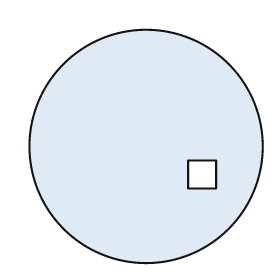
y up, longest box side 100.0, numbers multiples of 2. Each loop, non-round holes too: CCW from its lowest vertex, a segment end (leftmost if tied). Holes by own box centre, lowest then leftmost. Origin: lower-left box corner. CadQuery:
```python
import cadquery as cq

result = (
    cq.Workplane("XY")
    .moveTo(50.0, 50.0)
    .circle(50.0)
    .moveTo(68.0, 32.0)
    .lineTo(80.0, 32.0)
    .lineTo(80.0, 44.0)
    .lineTo(68.0, 44.0)
    .close()
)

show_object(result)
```